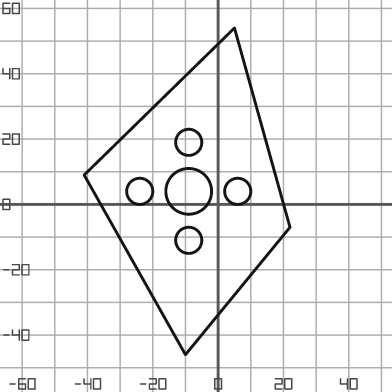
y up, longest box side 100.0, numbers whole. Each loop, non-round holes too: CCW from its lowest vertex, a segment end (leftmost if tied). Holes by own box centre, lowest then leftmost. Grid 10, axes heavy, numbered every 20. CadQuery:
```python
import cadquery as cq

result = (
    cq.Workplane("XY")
    .moveTo(-10.0, -46.0)
    .lineTo(22.0, -7.0)
    .lineTo(5.0, 54.0)
    .lineTo(-41.0, 9.0)
    .close()
    .moveTo(-9.0, -11.0)
    .circle(4.0)
    .moveTo(-24.0, 4.0)
    .circle(4.0)
    .moveTo(-9.0, 4.0)
    .circle(7.0)
    .moveTo(6.0, 4.0)
    .circle(4.0)
    .moveTo(-9.0, 19.0)
    .circle(4.0)
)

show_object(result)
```